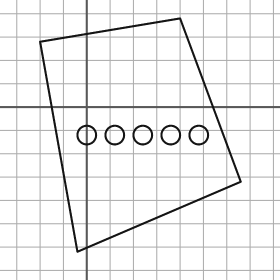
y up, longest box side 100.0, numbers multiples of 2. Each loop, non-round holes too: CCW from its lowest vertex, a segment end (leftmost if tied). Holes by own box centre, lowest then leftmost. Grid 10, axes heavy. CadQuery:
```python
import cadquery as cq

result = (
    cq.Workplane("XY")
    .moveTo(-4.0, -62.0)
    .lineTo(66.0, -32.0)
    .lineTo(40.0, 38.0)
    .lineTo(-20.0, 28.0)
    .close()
    .moveTo(0.0, -12.0)
    .circle(4.0)
    .moveTo(12.0, -12.0)
    .circle(4.0)
    .moveTo(24.0, -12.0)
    .circle(4.0)
    .moveTo(36.0, -12.0)
    .circle(4.0)
    .moveTo(48.0, -12.0)
    .circle(4.0)
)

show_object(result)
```